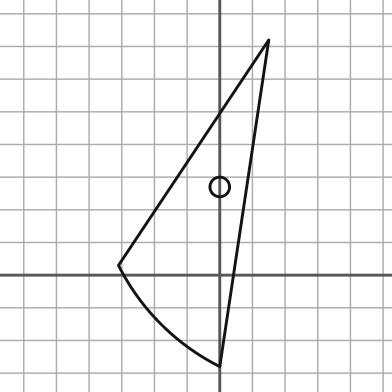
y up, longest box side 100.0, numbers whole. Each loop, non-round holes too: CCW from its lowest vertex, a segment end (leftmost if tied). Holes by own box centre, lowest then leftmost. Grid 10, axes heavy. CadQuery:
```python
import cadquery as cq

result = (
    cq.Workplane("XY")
    .moveTo(0.0, -28.0)
    .lineTo(15.0, 72.0)
    .lineTo(-31.0, 3.0)
    .threePointArc((-18.0, -15.0), (0.0, -28.0))
    .close()
    .moveTo(0.0, 27.0)
    .circle(3.0)
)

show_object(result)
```